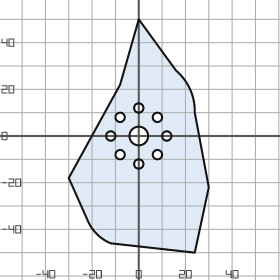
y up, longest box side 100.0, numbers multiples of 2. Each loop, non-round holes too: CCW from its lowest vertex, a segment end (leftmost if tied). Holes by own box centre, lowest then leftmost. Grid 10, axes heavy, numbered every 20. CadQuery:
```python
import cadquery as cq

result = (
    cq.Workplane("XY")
    .moveTo(24.0, -50.0)
    .lineTo(30.0, -22.0)
    .lineTo(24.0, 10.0)
    .threePointArc((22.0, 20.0), (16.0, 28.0))
    .lineTo(0.0, 50.0)
    .lineTo(-8.0, 22.0)
    .lineTo(-30.0, -18.0)
    .lineTo(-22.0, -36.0)
    .threePointArc((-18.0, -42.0), (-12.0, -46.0))
    .close()
    .moveTo(0.0, -12.0)
    .circle(2.0)
    .moveTo(-8.0, -8.0)
    .circle(2.0)
    .moveTo(8.0, -8.0)
    .circle(2.0)
    .moveTo(-12.0, 0.0)
    .circle(2.0)
    .moveTo(0.0, 0.0)
    .circle(4.0)
    .moveTo(12.0, 0.0)
    .circle(2.0)
    .moveTo(-8.0, 8.0)
    .circle(2.0)
    .moveTo(8.0, 8.0)
    .circle(2.0)
    .moveTo(0.0, 12.0)
    .circle(2.0)
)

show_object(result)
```